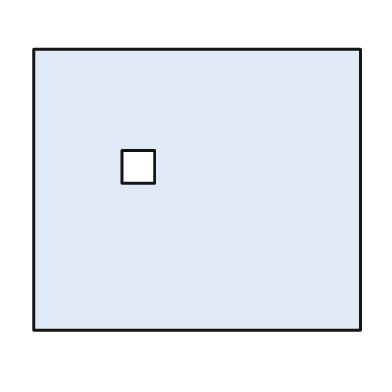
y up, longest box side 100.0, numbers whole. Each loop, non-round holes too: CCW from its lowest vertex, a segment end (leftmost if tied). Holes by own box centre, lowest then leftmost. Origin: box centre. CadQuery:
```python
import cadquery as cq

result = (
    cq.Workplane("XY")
    .moveTo(-50.0, -43.0)
    .lineTo(50.0, -43.0)
    .lineTo(50.0, 43.0)
    .lineTo(-50.0, 43.0)
    .close()
    .moveTo(-23.0, 2.0)
    .lineTo(-13.0, 2.0)
    .lineTo(-13.0, 12.0)
    .lineTo(-23.0, 12.0)
    .close()
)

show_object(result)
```